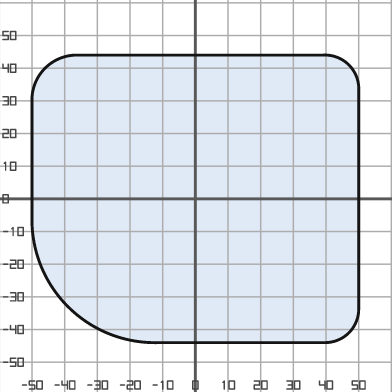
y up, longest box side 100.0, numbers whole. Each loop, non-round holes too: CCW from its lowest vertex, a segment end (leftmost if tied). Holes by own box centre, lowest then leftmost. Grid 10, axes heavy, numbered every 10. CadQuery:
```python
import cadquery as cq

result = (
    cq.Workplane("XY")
    .moveTo(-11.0, -44.0)
    .lineTo(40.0, -44.0)
    .threePointArc((47.0, -41.0), (50.0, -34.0))
    .lineTo(50.0, 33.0)
    .threePointArc((47.0, 41.0), (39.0, 44.0))
    .lineTo(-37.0, 44.0)
    .threePointArc((-46.0, 40.0), (-50.0, 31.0))
    .lineTo(-50.0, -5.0)
    .threePointArc((-39.0, -33.0), (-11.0, -44.0))
    .close()
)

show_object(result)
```